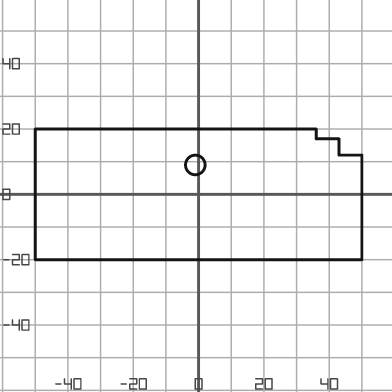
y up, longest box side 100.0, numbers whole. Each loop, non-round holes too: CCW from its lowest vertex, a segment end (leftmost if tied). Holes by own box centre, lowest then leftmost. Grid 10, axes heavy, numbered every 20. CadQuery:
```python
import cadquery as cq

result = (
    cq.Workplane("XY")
    .moveTo(-50.0, -20.0)
    .lineTo(50.0, -20.0)
    .lineTo(50.0, 12.0)
    .lineTo(43.0, 12.0)
    .lineTo(43.0, 17.0)
    .lineTo(36.0, 17.0)
    .lineTo(36.0, 20.0)
    .lineTo(-50.0, 20.0)
    .close()
    .moveTo(-1.0, 9.0)
    .circle(3.0)
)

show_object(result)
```